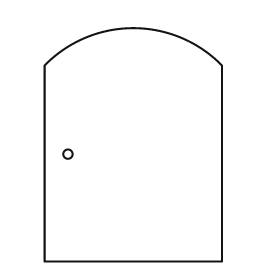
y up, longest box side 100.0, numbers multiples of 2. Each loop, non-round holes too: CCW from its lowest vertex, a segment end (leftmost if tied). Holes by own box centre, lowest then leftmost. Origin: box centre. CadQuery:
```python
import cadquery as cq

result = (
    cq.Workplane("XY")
    .moveTo(-38.0, -50.0)
    .lineTo(38.0, -50.0)
    .lineTo(38.0, 34.0)
    .threePointArc((0.0, 50.0), (-38.0, 34.0))
    .close()
    .moveTo(-28.0, -4.0)
    .circle(2.0)
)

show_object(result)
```